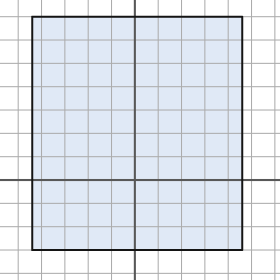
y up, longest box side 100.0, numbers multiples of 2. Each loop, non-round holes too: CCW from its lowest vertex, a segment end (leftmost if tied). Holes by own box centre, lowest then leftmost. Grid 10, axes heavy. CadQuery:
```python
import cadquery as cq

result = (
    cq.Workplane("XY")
    .moveTo(-44.0, -30.0)
    .lineTo(46.0, -30.0)
    .lineTo(46.0, 70.0)
    .lineTo(-44.0, 70.0)
    .close()
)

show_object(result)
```